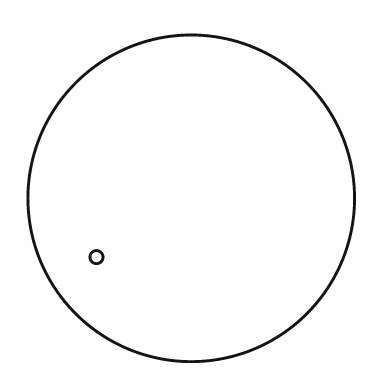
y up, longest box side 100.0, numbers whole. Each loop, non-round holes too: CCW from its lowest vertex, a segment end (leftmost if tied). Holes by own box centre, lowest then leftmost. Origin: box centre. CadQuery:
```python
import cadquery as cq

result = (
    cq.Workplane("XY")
    .moveTo(0.0, 0.0)
    .circle(50.0)
    .moveTo(-29.0, -18.0)
    .circle(2.0)
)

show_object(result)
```